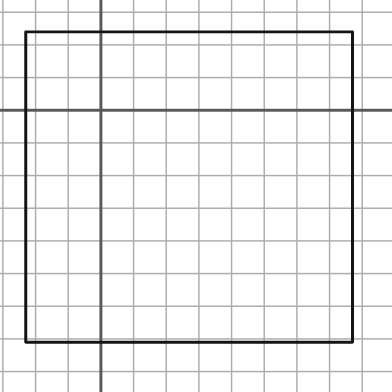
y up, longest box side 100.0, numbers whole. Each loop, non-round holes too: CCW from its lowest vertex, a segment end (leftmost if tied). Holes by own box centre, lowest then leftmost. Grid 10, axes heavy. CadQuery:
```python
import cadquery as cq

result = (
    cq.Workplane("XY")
    .moveTo(-23.0, -71.0)
    .lineTo(77.0, -71.0)
    .lineTo(77.0, 24.0)
    .lineTo(-23.0, 24.0)
    .close()
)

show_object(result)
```